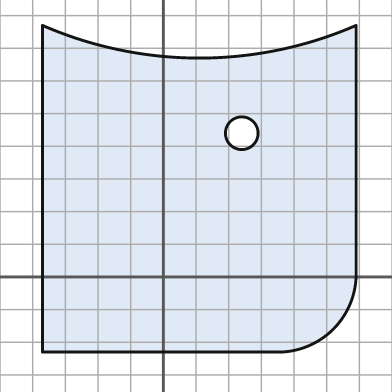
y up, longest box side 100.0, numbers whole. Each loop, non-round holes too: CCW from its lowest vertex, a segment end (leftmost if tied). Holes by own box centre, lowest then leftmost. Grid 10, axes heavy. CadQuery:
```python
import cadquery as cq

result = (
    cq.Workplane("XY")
    .moveTo(-37.0, -23.0)
    .lineTo(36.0, -23.0)
    .threePointArc((52.0, -16.0), (59.0, 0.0))
    .lineTo(59.0, 77.0)
    .threePointArc((11.0, 67.0), (-37.0, 77.0))
    .close()
    .moveTo(24.0, 44.0)
    .circle(5.0)
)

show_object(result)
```